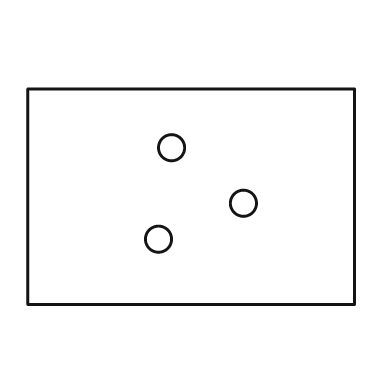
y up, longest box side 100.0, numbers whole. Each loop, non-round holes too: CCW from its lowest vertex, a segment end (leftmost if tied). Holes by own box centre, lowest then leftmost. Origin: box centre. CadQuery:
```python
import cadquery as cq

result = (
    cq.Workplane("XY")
    .moveTo(-50.0, -33.0)
    .lineTo(50.0, -33.0)
    .lineTo(50.0, 33.0)
    .lineTo(-50.0, 33.0)
    .close()
    .moveTo(-10.0, -13.0)
    .circle(4.0)
    .moveTo(16.0, -2.0)
    .circle(4.0)
    .moveTo(-6.0, 15.0)
    .circle(4.0)
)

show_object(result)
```